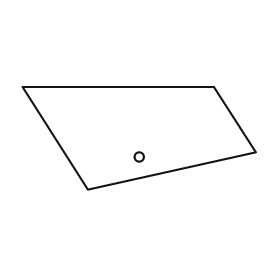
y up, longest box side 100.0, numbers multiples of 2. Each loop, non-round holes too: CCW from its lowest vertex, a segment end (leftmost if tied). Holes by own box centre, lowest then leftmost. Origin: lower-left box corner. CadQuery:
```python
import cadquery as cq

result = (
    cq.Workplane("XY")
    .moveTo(28.0, 0.0)
    .lineTo(100.0, 16.0)
    .lineTo(82.0, 44.0)
    .lineTo(0.0, 44.0)
    .close()
    .moveTo(50.0, 14.0)
    .circle(2.0)
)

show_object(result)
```